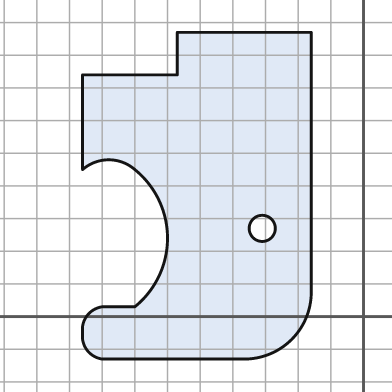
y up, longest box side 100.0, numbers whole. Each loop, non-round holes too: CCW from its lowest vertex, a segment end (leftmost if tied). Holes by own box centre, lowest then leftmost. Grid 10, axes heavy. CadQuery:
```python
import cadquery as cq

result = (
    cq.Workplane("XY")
    .moveTo(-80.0, -13.0)
    .lineTo(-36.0, -13.0)
    .threePointArc((-22.0, -7.0), (-16.0, 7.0))
    .lineTo(-16.0, 87.0)
    .lineTo(-57.0, 87.0)
    .lineTo(-57.0, 74.0)
    .lineTo(-86.0, 74.0)
    .lineTo(-86.0, 45.0)
    .threePointArc((-78.0, 48.0), (-70.0, 45.0))
    .threePointArc((-60.0, 24.0), (-70.0, 3.0))
    .lineTo(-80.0, 3.0)
    .threePointArc((-84.0, 1.0), (-86.0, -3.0))
    .lineTo(-86.0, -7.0)
    .threePointArc((-84.0, -11.0), (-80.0, -13.0))
    .close()
    .moveTo(-31.0, 27.0)
    .circle(4.0)
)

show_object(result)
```